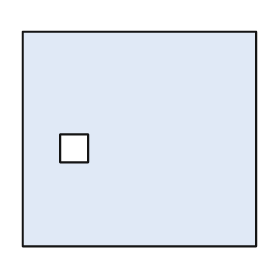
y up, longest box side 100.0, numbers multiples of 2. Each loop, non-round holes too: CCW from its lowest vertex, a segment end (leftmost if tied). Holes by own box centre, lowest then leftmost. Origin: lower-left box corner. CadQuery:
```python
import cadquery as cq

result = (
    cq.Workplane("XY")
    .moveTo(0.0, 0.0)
    .lineTo(100.0, 0.0)
    .lineTo(100.0, 92.0)
    .lineTo(0.0, 92.0)
    .close()
    .moveTo(16.0, 36.0)
    .lineTo(28.0, 36.0)
    .lineTo(28.0, 48.0)
    .lineTo(16.0, 48.0)
    .close()
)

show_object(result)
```